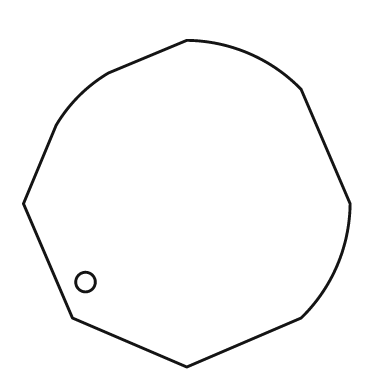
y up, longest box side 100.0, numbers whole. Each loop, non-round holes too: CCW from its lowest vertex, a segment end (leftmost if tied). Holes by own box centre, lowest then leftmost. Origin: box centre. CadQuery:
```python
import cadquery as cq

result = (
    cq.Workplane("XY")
    .moveTo(0.0, -50.0)
    .lineTo(35.0, -35.0)
    .threePointArc((46.0, -19.0), (50.0, 0.0))
    .lineTo(35.0, 35.0)
    .threePointArc((19.0, 46.0), (0.0, 50.0))
    .lineTo(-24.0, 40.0)
    .threePointArc((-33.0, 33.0), (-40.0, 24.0))
    .lineTo(-50.0, 0.0)
    .lineTo(-35.0, -35.0)
    .close()
    .moveTo(-31.0, -24.0)
    .circle(3.0)
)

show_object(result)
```